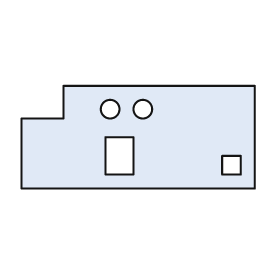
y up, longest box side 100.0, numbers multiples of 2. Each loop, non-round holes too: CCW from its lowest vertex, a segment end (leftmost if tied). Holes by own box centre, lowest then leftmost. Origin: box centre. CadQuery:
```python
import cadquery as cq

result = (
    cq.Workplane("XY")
    .moveTo(-50.0, -22.0)
    .lineTo(50.0, -22.0)
    .lineTo(50.0, 22.0)
    .lineTo(-32.0, 22.0)
    .lineTo(-32.0, 8.0)
    .lineTo(-50.0, 8.0)
    .close()
    .moveTo(36.0, -16.0)
    .lineTo(44.0, -16.0)
    .lineTo(44.0, -8.0)
    .lineTo(36.0, -8.0)
    .close()
    .moveTo(-14.0, -16.0)
    .lineTo(-2.0, -16.0)
    .lineTo(-2.0, 0.0)
    .lineTo(-14.0, 0.0)
    .close()
    .moveTo(-12.0, 12.0)
    .circle(4.0)
    .moveTo(2.0, 12.0)
    .circle(4.0)
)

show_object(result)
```